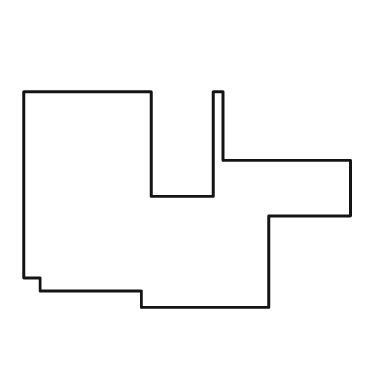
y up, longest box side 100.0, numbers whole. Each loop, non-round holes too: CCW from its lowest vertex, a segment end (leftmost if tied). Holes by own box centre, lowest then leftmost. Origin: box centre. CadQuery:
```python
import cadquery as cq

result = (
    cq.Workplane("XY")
    .moveTo(-14.0, -33.0)
    .lineTo(25.0, -33.0)
    .lineTo(25.0, -5.0)
    .lineTo(50.0, -5.0)
    .lineTo(50.0, 12.0)
    .lineTo(11.0, 12.0)
    .lineTo(11.0, 33.0)
    .lineTo(8.0, 33.0)
    .lineTo(8.0, 1.0)
    .lineTo(-11.0, 1.0)
    .lineTo(-11.0, 33.0)
    .lineTo(-50.0, 33.0)
    .lineTo(-50.0, -24.0)
    .lineTo(-45.0, -24.0)
    .lineTo(-45.0, -28.0)
    .lineTo(-14.0, -28.0)
    .close()
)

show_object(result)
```